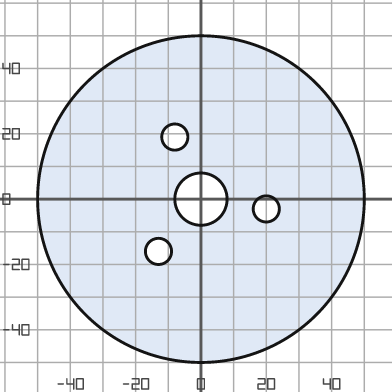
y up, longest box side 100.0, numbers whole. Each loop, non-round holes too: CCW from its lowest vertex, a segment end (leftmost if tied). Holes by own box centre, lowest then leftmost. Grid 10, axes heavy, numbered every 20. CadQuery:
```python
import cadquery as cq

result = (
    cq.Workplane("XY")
    .moveTo(0.0, 0.0)
    .circle(50.0)
    .moveTo(-13.0, -16.0)
    .circle(4.0)
    .moveTo(20.0, -3.0)
    .circle(4.0)
    .moveTo(0.0, 0.0)
    .circle(8.0)
    .moveTo(-8.0, 19.0)
    .circle(4.0)
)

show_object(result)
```